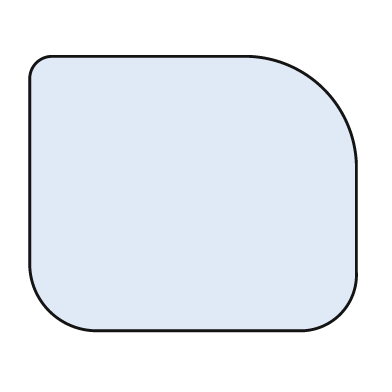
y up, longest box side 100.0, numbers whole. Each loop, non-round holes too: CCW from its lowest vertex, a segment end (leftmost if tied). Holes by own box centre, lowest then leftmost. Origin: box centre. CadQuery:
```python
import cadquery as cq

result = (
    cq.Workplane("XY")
    .moveTo(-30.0, -42.0)
    .lineTo(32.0, -42.0)
    .threePointArc((45.0, -37.0), (50.0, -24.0))
    .lineTo(50.0, 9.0)
    .threePointArc((40.0, 32.0), (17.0, 42.0))
    .lineTo(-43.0, 42.0)
    .threePointArc((-48.0, 40.0), (-50.0, 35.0))
    .lineTo(-50.0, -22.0)
    .threePointArc((-44.0, -36.0), (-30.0, -42.0))
    .close()
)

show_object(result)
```